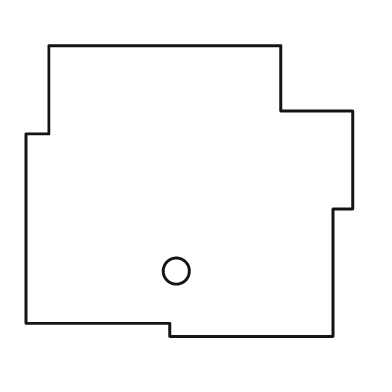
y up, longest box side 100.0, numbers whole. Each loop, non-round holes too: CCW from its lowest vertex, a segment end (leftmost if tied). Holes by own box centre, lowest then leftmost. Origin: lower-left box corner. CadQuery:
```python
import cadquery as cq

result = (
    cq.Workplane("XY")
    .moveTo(44.0, 0.0)
    .lineTo(94.0, 0.0)
    .lineTo(94.0, 39.0)
    .lineTo(100.0, 39.0)
    .lineTo(100.0, 69.0)
    .lineTo(78.0, 69.0)
    .lineTo(78.0, 89.0)
    .lineTo(7.0, 89.0)
    .lineTo(7.0, 62.0)
    .lineTo(0.0, 62.0)
    .lineTo(0.0, 4.0)
    .lineTo(44.0, 4.0)
    .close()
    .moveTo(46.0, 20.0)
    .circle(4.0)
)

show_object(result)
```